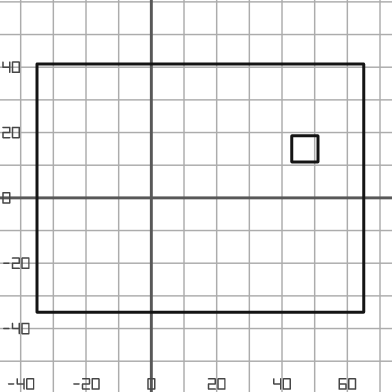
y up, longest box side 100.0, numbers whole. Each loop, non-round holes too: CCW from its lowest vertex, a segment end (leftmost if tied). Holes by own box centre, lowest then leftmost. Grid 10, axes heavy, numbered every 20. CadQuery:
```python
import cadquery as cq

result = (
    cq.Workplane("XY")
    .moveTo(-35.0, -35.0)
    .lineTo(65.0, -35.0)
    .lineTo(65.0, 41.0)
    .lineTo(-35.0, 41.0)
    .close()
    .moveTo(43.0, 11.0)
    .lineTo(51.0, 11.0)
    .lineTo(51.0, 19.0)
    .lineTo(43.0, 19.0)
    .close()
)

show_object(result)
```